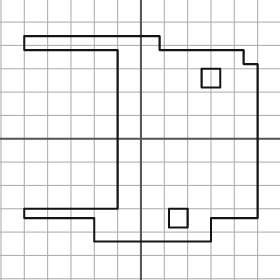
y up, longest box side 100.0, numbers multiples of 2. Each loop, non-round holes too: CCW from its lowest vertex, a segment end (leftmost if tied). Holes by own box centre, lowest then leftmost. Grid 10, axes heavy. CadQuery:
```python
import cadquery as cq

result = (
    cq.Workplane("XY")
    .moveTo(-20.0, -44.0)
    .lineTo(30.0, -44.0)
    .lineTo(30.0, -34.0)
    .lineTo(50.0, -34.0)
    .lineTo(50.0, 32.0)
    .lineTo(44.0, 32.0)
    .lineTo(44.0, 38.0)
    .lineTo(8.0, 38.0)
    .lineTo(8.0, 44.0)
    .lineTo(-50.0, 44.0)
    .lineTo(-50.0, 38.0)
    .lineTo(-10.0, 38.0)
    .lineTo(-10.0, -30.0)
    .lineTo(-50.0, -30.0)
    .lineTo(-50.0, -34.0)
    .lineTo(-20.0, -34.0)
    .close()
    .moveTo(12.0, -38.0)
    .lineTo(20.0, -38.0)
    .lineTo(20.0, -30.0)
    .lineTo(12.0, -30.0)
    .close()
    .moveTo(26.0, 22.0)
    .lineTo(34.0, 22.0)
    .lineTo(34.0, 30.0)
    .lineTo(26.0, 30.0)
    .close()
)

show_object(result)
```